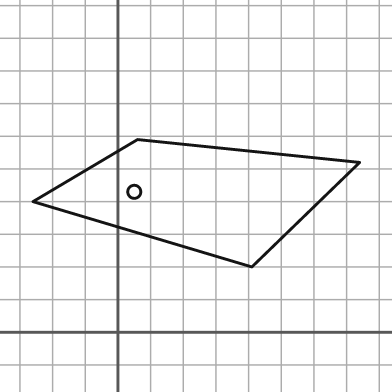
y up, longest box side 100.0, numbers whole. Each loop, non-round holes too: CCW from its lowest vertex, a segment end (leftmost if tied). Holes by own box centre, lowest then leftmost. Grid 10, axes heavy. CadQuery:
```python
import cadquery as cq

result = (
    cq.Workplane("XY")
    .moveTo(41.0, 20.0)
    .lineTo(74.0, 52.0)
    .lineTo(6.0, 59.0)
    .lineTo(-26.0, 40.0)
    .close()
    .moveTo(5.0, 43.0)
    .circle(2.0)
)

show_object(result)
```